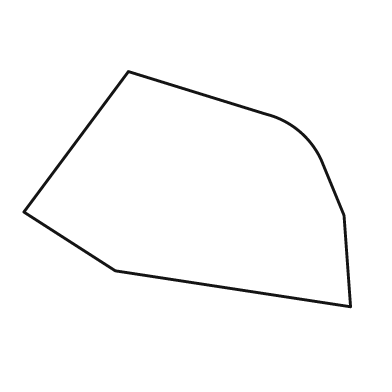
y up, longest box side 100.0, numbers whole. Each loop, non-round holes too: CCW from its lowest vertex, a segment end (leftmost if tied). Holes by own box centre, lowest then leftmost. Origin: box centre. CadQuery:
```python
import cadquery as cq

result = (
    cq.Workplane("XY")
    .moveTo(50.0, -36.0)
    .lineTo(48.0, -8.0)
    .lineTo(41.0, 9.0)
    .threePointArc((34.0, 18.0), (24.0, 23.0))
    .lineTo(-18.0, 36.0)
    .lineTo(-50.0, -7.0)
    .lineTo(-22.0, -25.0)
    .close()
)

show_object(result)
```